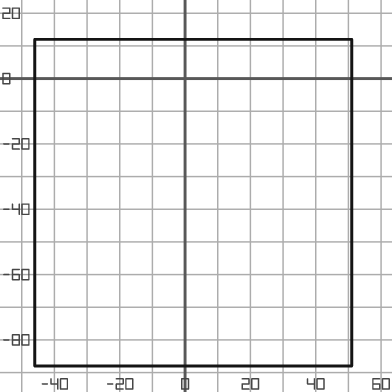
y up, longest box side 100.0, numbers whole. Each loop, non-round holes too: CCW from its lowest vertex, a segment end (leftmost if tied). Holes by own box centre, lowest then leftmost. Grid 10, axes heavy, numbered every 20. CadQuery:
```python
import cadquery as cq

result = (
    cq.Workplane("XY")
    .moveTo(-46.0, -88.0)
    .lineTo(51.0, -88.0)
    .lineTo(51.0, 12.0)
    .lineTo(-46.0, 12.0)
    .close()
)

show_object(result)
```